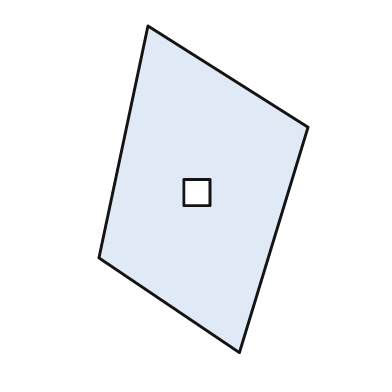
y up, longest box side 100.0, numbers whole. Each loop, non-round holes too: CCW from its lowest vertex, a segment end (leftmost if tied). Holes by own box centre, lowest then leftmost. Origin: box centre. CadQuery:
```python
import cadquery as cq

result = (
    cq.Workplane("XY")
    .moveTo(11.0, -50.0)
    .lineTo(32.0, 19.0)
    .lineTo(-17.0, 50.0)
    .lineTo(-32.0, -21.0)
    .close()
    .moveTo(-6.0, -5.0)
    .lineTo(2.0, -5.0)
    .lineTo(2.0, 3.0)
    .lineTo(-6.0, 3.0)
    .close()
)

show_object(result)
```